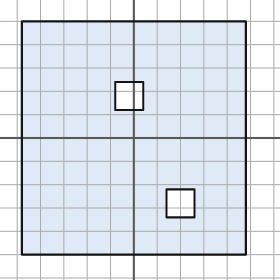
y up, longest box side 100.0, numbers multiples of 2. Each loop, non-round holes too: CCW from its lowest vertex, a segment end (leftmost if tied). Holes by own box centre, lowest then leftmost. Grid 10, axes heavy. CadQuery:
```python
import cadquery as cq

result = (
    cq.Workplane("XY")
    .moveTo(-48.0, -50.0)
    .lineTo(48.0, -50.0)
    .lineTo(48.0, 50.0)
    .lineTo(-48.0, 50.0)
    .close()
    .moveTo(14.0, -34.0)
    .lineTo(26.0, -34.0)
    .lineTo(26.0, -22.0)
    .lineTo(14.0, -22.0)
    .close()
    .moveTo(-8.0, 12.0)
    .lineTo(4.0, 12.0)
    .lineTo(4.0, 24.0)
    .lineTo(-8.0, 24.0)
    .close()
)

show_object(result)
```